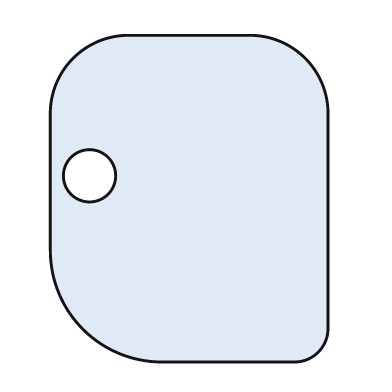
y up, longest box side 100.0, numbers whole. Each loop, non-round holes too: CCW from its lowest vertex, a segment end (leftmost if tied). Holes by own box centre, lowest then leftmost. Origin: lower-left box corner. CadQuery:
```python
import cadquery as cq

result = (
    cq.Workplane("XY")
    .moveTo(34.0, 0.0)
    .lineTo(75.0, 0.0)
    .threePointArc((82.0, 3.0), (85.0, 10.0))
    .lineTo(85.0, 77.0)
    .threePointArc((78.0, 93.0), (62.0, 100.0))
    .lineTo(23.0, 100.0)
    .threePointArc((7.0, 93.0), (0.0, 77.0))
    .lineTo(0.0, 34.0)
    .threePointArc((10.0, 10.0), (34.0, 0.0))
    .close()
    .moveTo(12.0, 57.0)
    .circle(8.0)
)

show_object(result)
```